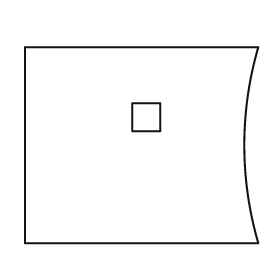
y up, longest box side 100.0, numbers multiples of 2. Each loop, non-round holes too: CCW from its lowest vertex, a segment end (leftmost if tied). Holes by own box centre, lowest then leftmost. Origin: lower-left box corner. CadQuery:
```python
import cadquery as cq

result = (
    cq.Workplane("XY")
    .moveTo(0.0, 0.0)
    .lineTo(100.0, 0.0)
    .threePointArc((94.0, 42.0), (100.0, 84.0))
    .lineTo(0.0, 84.0)
    .close()
    .moveTo(46.0, 48.0)
    .lineTo(58.0, 48.0)
    .lineTo(58.0, 60.0)
    .lineTo(46.0, 60.0)
    .close()
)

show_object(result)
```